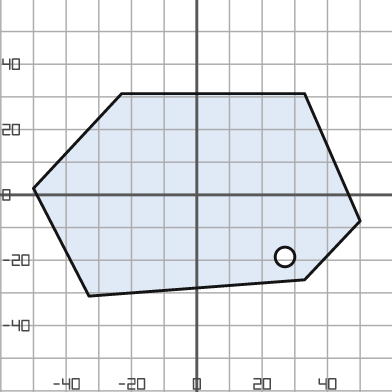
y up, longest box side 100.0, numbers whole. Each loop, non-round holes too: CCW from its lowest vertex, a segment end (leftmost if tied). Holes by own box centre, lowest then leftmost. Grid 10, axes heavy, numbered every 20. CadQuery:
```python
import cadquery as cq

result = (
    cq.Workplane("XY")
    .moveTo(-33.0, -31.0)
    .lineTo(33.0, -26.0)
    .lineTo(50.0, -8.0)
    .lineTo(33.0, 31.0)
    .lineTo(-23.0, 31.0)
    .lineTo(-50.0, 2.0)
    .close()
    .moveTo(27.0, -19.0)
    .circle(3.0)
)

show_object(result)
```